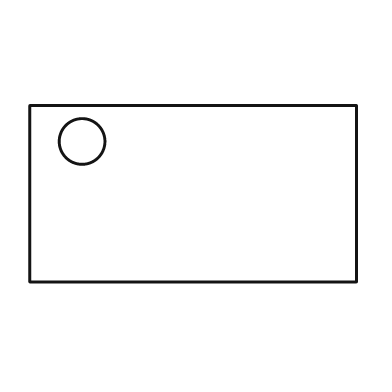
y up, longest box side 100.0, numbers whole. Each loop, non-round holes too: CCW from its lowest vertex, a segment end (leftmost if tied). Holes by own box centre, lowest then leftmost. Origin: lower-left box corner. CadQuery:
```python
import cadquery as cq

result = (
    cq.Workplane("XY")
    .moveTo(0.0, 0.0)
    .lineTo(100.0, 0.0)
    .lineTo(100.0, 54.0)
    .lineTo(0.0, 54.0)
    .close()
    .moveTo(16.0, 43.0)
    .circle(7.0)
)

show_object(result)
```